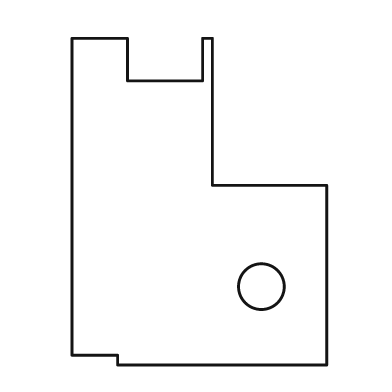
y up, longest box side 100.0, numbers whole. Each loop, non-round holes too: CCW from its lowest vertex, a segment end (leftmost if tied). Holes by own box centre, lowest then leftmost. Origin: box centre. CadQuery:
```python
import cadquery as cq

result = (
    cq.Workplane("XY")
    .moveTo(-25.0, -50.0)
    .lineTo(39.0, -50.0)
    .lineTo(39.0, 5.0)
    .lineTo(4.0, 5.0)
    .lineTo(4.0, 50.0)
    .lineTo(1.0, 50.0)
    .lineTo(1.0, 37.0)
    .lineTo(-22.0, 37.0)
    .lineTo(-22.0, 50.0)
    .lineTo(-39.0, 50.0)
    .lineTo(-39.0, -47.0)
    .lineTo(-25.0, -47.0)
    .close()
    .moveTo(19.0, -26.0)
    .circle(7.0)
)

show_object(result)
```